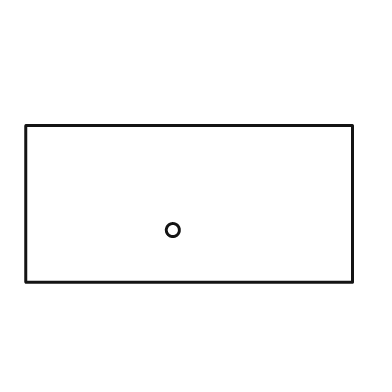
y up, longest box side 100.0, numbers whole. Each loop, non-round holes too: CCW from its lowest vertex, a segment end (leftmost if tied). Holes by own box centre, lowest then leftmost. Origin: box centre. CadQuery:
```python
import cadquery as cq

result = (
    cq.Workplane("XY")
    .moveTo(-50.0, -24.0)
    .lineTo(50.0, -24.0)
    .lineTo(50.0, 24.0)
    .lineTo(-50.0, 24.0)
    .close()
    .moveTo(-5.0, -8.0)
    .circle(2.0)
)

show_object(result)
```